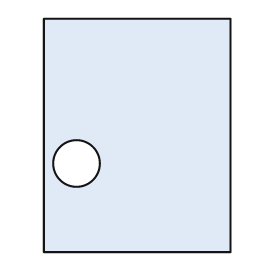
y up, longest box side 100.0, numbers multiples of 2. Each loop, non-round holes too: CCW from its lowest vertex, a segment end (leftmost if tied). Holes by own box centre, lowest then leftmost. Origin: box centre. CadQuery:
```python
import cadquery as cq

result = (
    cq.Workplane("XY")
    .moveTo(-40.0, -50.0)
    .lineTo(40.0, -50.0)
    .lineTo(40.0, 50.0)
    .lineTo(-40.0, 50.0)
    .close()
    .moveTo(-26.0, -12.0)
    .circle(10.0)
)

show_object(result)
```